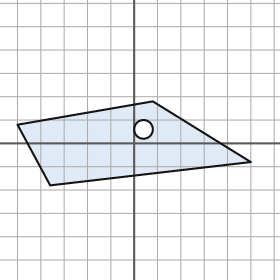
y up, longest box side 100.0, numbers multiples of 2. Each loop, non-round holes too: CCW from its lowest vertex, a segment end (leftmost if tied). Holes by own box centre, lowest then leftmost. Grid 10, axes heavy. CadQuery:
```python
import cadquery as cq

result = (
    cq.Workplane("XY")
    .moveTo(-36.0, -18.0)
    .lineTo(50.0, -8.0)
    .lineTo(8.0, 18.0)
    .lineTo(-50.0, 8.0)
    .close()
    .moveTo(4.0, 6.0)
    .circle(4.0)
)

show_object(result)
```